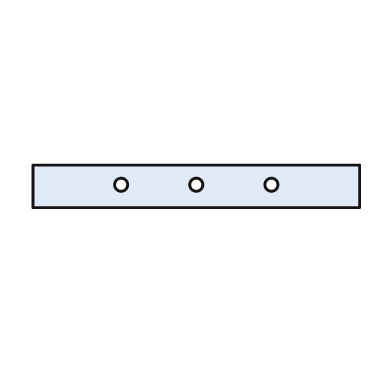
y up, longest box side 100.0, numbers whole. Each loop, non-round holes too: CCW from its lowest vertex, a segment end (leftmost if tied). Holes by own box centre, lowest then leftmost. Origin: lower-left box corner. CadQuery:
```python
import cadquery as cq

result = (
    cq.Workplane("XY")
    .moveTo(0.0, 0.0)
    .lineTo(100.0, 0.0)
    .lineTo(100.0, 13.0)
    .lineTo(0.0, 13.0)
    .close()
    .moveTo(27.0, 7.0)
    .circle(2.0)
    .moveTo(50.0, 7.0)
    .circle(2.0)
    .moveTo(73.0, 7.0)
    .circle(2.0)
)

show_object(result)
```